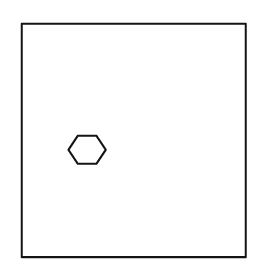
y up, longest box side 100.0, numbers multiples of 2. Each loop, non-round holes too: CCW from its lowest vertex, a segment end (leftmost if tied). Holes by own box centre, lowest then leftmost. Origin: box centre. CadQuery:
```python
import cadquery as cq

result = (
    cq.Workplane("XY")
    .moveTo(-48.0, -50.0)
    .lineTo(48.0, -50.0)
    .lineTo(48.0, 50.0)
    .lineTo(-48.0, 50.0)
    .close()
    .moveTo(-24.0, -10.0)
    .lineTo(-16.0, -10.0)
    .lineTo(-12.0, -4.0)
    .lineTo(-16.0, 2.0)
    .lineTo(-24.0, 2.0)
    .lineTo(-28.0, -4.0)
    .close()
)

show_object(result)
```